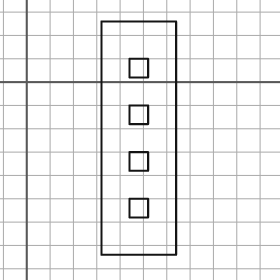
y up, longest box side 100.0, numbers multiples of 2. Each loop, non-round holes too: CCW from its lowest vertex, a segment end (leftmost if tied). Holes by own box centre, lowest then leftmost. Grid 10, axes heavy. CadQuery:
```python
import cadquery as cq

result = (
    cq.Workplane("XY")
    .moveTo(32.0, -74.0)
    .lineTo(64.0, -74.0)
    .lineTo(64.0, 26.0)
    .lineTo(32.0, 26.0)
    .close()
    .moveTo(44.0, -58.0)
    .lineTo(52.0, -58.0)
    .lineTo(52.0, -50.0)
    .lineTo(44.0, -50.0)
    .close()
    .moveTo(44.0, -38.0)
    .lineTo(52.0, -38.0)
    .lineTo(52.0, -30.0)
    .lineTo(44.0, -30.0)
    .close()
    .moveTo(44.0, -18.0)
    .lineTo(52.0, -18.0)
    .lineTo(52.0, -10.0)
    .lineTo(44.0, -10.0)
    .close()
    .moveTo(44.0, 2.0)
    .lineTo(52.0, 2.0)
    .lineTo(52.0, 10.0)
    .lineTo(44.0, 10.0)
    .close()
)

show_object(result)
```